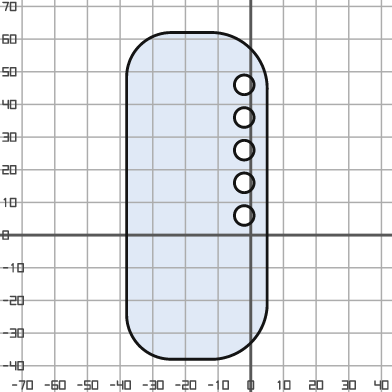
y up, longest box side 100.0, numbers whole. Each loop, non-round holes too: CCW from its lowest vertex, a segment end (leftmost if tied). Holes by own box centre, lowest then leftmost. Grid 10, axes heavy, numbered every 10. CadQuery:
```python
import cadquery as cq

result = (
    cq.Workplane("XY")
    .moveTo(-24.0, -38.0)
    .lineTo(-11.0, -38.0)
    .threePointArc((0.0, -33.0), (5.0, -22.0))
    .lineTo(5.0, 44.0)
    .threePointArc((0.0, 57.0), (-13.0, 62.0))
    .lineTo(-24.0, 62.0)
    .threePointArc((-34.0, 58.0), (-38.0, 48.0))
    .lineTo(-38.0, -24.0)
    .threePointArc((-34.0, -34.0), (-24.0, -38.0))
    .close()
    .moveTo(-2.0, 6.0)
    .circle(3.0)
    .moveTo(-2.0, 16.0)
    .circle(3.0)
    .moveTo(-2.0, 26.0)
    .circle(3.0)
    .moveTo(-2.0, 36.0)
    .circle(3.0)
    .moveTo(-2.0, 46.0)
    .circle(3.0)
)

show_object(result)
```